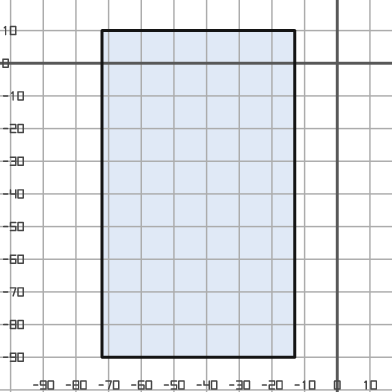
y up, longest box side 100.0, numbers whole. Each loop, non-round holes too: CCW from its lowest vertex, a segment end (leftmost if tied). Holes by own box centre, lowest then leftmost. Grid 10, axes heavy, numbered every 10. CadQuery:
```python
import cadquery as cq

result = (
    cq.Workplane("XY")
    .moveTo(-72.0, -90.0)
    .lineTo(-13.0, -90.0)
    .lineTo(-13.0, 10.0)
    .lineTo(-72.0, 10.0)
    .close()
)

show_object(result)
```